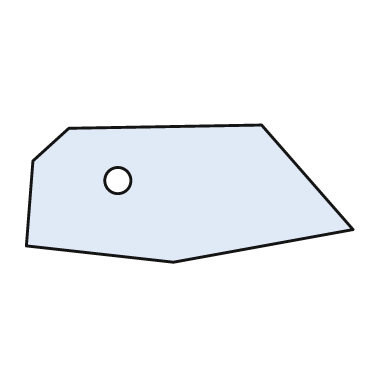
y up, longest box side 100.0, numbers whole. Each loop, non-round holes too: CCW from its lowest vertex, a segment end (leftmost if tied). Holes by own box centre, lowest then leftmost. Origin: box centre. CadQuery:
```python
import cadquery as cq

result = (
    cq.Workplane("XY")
    .moveTo(-5.0, -21.0)
    .lineTo(50.0, -11.0)
    .lineTo(22.0, 21.0)
    .lineTo(-37.0, 20.0)
    .lineTo(-48.0, 10.0)
    .lineTo(-50.0, -16.0)
    .close()
    .moveTo(-22.0, 4.0)
    .circle(4.0)
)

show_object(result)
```